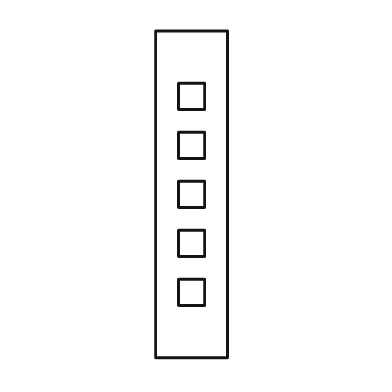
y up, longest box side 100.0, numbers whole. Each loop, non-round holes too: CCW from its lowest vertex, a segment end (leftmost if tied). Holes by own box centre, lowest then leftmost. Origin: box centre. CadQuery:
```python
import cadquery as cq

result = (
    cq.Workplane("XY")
    .moveTo(-11.0, -50.0)
    .lineTo(11.0, -50.0)
    .lineTo(11.0, 50.0)
    .lineTo(-11.0, 50.0)
    .close()
    .moveTo(-4.0, -34.0)
    .lineTo(4.0, -34.0)
    .lineTo(4.0, -26.0)
    .lineTo(-4.0, -26.0)
    .close()
    .moveTo(-4.0, -19.0)
    .lineTo(4.0, -19.0)
    .lineTo(4.0, -11.0)
    .lineTo(-4.0, -11.0)
    .close()
    .moveTo(-4.0, -4.0)
    .lineTo(4.0, -4.0)
    .lineTo(4.0, 4.0)
    .lineTo(-4.0, 4.0)
    .close()
    .moveTo(-4.0, 11.0)
    .lineTo(4.0, 11.0)
    .lineTo(4.0, 19.0)
    .lineTo(-4.0, 19.0)
    .close()
    .moveTo(-4.0, 26.0)
    .lineTo(4.0, 26.0)
    .lineTo(4.0, 34.0)
    .lineTo(-4.0, 34.0)
    .close()
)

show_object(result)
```